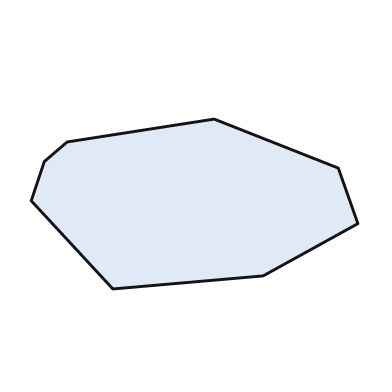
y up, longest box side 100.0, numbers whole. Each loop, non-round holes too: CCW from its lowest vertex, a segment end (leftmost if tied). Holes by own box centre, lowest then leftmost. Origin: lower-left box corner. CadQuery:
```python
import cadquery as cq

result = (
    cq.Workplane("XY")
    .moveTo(25.0, 0.0)
    .lineTo(71.0, 4.0)
    .lineTo(100.0, 20.0)
    .lineTo(94.0, 37.0)
    .lineTo(56.0, 52.0)
    .lineTo(11.0, 45.0)
    .lineTo(4.0, 39.0)
    .lineTo(0.0, 27.0)
    .close()
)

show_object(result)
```